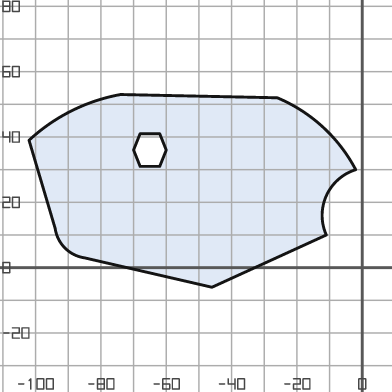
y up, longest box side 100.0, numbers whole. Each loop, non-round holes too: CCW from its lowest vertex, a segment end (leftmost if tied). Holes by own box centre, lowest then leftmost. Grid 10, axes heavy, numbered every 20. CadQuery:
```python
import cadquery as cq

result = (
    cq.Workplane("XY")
    .moveTo(-46.0, -6.0)
    .lineTo(-11.0, 10.0)
    .threePointArc((-11.0, 22.0), (-2.0, 30.0))
    .threePointArc((-12.0, 43.0), (-26.0, 52.0))
    .lineTo(-74.0, 53.0)
    .threePointArc((-89.0, 48.0), (-102.0, 39.0))
    .lineTo(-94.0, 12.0)
    .threePointArc((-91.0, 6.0), (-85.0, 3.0))
    .close()
    .moveTo(-68.0, 31.0)
    .lineTo(-62.0, 31.0)
    .lineTo(-60.0, 36.0)
    .lineTo(-62.0, 41.0)
    .lineTo(-68.0, 41.0)
    .lineTo(-70.0, 36.0)
    .close()
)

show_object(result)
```